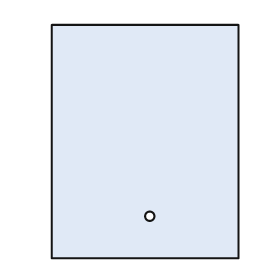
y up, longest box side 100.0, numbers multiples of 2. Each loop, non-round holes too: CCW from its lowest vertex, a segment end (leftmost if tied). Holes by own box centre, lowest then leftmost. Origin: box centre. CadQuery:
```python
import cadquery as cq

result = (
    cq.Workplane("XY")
    .moveTo(-40.0, -50.0)
    .lineTo(40.0, -50.0)
    .lineTo(40.0, 50.0)
    .lineTo(-40.0, 50.0)
    .close()
    .moveTo(2.0, -32.0)
    .circle(2.0)
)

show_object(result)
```